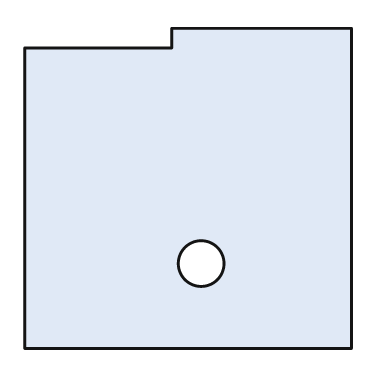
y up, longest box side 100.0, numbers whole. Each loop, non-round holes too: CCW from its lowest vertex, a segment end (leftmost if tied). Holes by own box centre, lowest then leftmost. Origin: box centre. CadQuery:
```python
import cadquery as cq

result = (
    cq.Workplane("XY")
    .moveTo(-50.0, -49.0)
    .lineTo(50.0, -49.0)
    .lineTo(50.0, 49.0)
    .lineTo(-5.0, 49.0)
    .lineTo(-5.0, 43.0)
    .lineTo(-50.0, 43.0)
    .close()
    .moveTo(4.0, -23.0)
    .circle(7.0)
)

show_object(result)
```